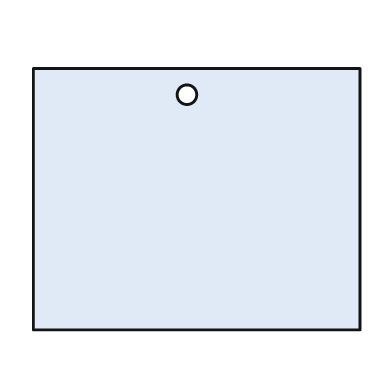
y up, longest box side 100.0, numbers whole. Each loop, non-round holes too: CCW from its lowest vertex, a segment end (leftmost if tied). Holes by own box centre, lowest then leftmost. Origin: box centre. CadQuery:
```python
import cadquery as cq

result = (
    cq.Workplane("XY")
    .moveTo(-50.0, -40.0)
    .lineTo(50.0, -40.0)
    .lineTo(50.0, 40.0)
    .lineTo(-50.0, 40.0)
    .close()
    .moveTo(-3.0, 32.0)
    .circle(3.0)
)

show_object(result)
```